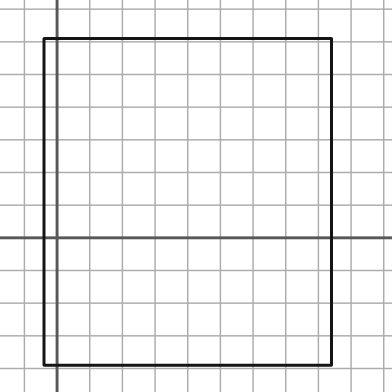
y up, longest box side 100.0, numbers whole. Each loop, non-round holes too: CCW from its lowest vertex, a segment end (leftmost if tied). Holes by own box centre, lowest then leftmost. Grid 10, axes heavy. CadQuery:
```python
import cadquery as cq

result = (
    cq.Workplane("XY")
    .moveTo(-4.0, -39.0)
    .lineTo(84.0, -39.0)
    .lineTo(84.0, 61.0)
    .lineTo(-4.0, 61.0)
    .close()
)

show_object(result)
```